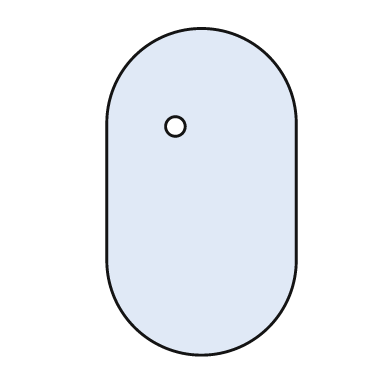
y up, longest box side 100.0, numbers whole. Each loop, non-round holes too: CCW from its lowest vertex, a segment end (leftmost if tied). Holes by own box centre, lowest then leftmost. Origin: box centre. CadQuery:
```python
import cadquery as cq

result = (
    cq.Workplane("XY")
    .moveTo(-29.0, -21.0)
    .threePointArc((0.0, -50.0), (29.0, -21.0))
    .lineTo(29.0, 21.0)
    .threePointArc((0.0, 50.0), (-29.0, 21.0))
    .close()
    .moveTo(-8.0, 20.0)
    .circle(3.0)
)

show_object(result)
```